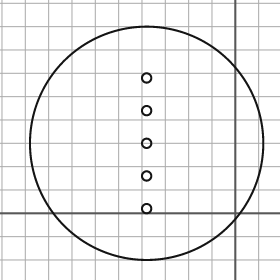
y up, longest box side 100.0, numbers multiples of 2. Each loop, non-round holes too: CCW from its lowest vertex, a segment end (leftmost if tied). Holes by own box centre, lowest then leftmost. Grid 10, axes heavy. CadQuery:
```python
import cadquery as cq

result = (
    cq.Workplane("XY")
    .moveTo(-38.0, 30.0)
    .circle(50.0)
    .moveTo(-38.0, 2.0)
    .circle(2.0)
    .moveTo(-38.0, 16.0)
    .circle(2.0)
    .moveTo(-38.0, 30.0)
    .circle(2.0)
    .moveTo(-38.0, 44.0)
    .circle(2.0)
    .moveTo(-38.0, 58.0)
    .circle(2.0)
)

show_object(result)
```